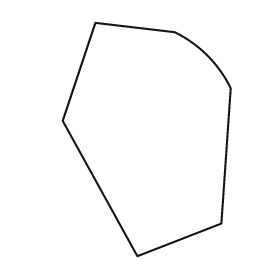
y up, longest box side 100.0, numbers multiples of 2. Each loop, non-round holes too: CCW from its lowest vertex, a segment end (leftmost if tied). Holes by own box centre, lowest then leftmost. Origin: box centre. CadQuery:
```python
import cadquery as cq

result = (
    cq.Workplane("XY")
    .moveTo(-4.0, -50.0)
    .lineTo(32.0, -36.0)
    .lineTo(36.0, 22.0)
    .threePointArc((26.0, 36.0), (12.0, 46.0))
    .lineTo(-22.0, 50.0)
    .lineTo(-36.0, 8.0)
    .close()
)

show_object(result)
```